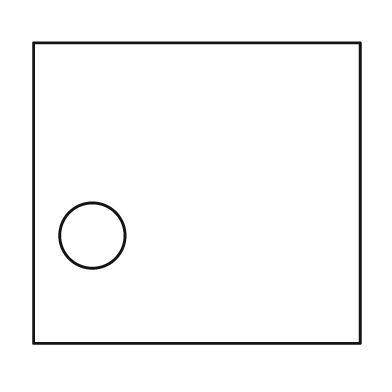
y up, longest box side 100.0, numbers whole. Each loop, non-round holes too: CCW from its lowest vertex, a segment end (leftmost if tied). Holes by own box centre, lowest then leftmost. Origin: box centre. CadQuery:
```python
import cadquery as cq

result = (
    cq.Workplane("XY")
    .moveTo(-50.0, -46.0)
    .lineTo(50.0, -46.0)
    .lineTo(50.0, 46.0)
    .lineTo(-50.0, 46.0)
    .close()
    .moveTo(-32.0, -13.0)
    .circle(10.0)
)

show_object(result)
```